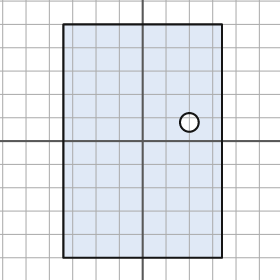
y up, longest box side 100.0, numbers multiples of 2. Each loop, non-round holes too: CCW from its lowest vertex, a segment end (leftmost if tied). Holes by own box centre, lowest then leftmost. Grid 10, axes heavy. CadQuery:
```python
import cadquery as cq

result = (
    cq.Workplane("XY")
    .moveTo(-34.0, -50.0)
    .lineTo(34.0, -50.0)
    .lineTo(34.0, 50.0)
    .lineTo(-34.0, 50.0)
    .close()
    .moveTo(20.0, 8.0)
    .circle(4.0)
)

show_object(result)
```